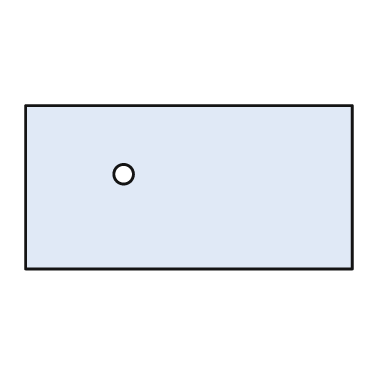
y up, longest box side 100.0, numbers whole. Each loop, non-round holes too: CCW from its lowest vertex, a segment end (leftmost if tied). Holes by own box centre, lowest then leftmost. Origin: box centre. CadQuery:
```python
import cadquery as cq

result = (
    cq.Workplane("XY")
    .moveTo(-50.0, -25.0)
    .lineTo(50.0, -25.0)
    .lineTo(50.0, 25.0)
    .lineTo(-50.0, 25.0)
    .close()
    .moveTo(-20.0, 4.0)
    .circle(3.0)
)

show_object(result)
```